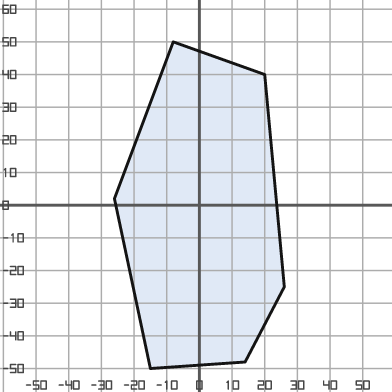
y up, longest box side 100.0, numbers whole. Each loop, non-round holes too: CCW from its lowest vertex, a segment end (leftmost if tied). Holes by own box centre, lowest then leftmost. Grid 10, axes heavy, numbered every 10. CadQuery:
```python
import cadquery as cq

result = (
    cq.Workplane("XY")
    .moveTo(-15.0, -50.0)
    .lineTo(14.0, -48.0)
    .lineTo(26.0, -25.0)
    .lineTo(20.0, 40.0)
    .lineTo(-8.0, 50.0)
    .lineTo(-26.0, 2.0)
    .close()
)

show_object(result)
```